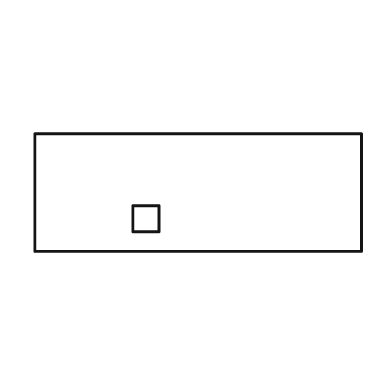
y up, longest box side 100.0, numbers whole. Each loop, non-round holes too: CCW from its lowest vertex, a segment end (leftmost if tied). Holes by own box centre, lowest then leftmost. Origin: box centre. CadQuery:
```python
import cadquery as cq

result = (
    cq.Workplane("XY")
    .moveTo(-50.0, -18.0)
    .lineTo(50.0, -18.0)
    .lineTo(50.0, 18.0)
    .lineTo(-50.0, 18.0)
    .close()
    .moveTo(-20.0, -12.0)
    .lineTo(-12.0, -12.0)
    .lineTo(-12.0, -4.0)
    .lineTo(-20.0, -4.0)
    .close()
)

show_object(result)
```